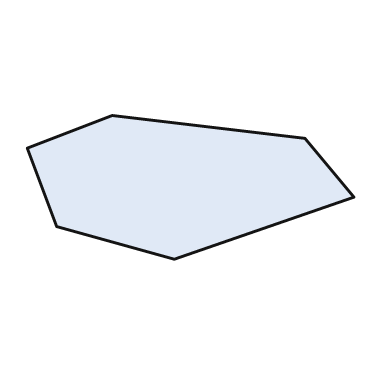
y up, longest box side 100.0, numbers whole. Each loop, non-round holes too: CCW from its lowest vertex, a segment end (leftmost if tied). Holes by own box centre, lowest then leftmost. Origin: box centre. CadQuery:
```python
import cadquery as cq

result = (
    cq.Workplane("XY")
    .moveTo(-5.0, -22.0)
    .lineTo(50.0, -3.0)
    .lineTo(35.0, 15.0)
    .lineTo(-24.0, 22.0)
    .lineTo(-50.0, 12.0)
    .lineTo(-41.0, -12.0)
    .close()
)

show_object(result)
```